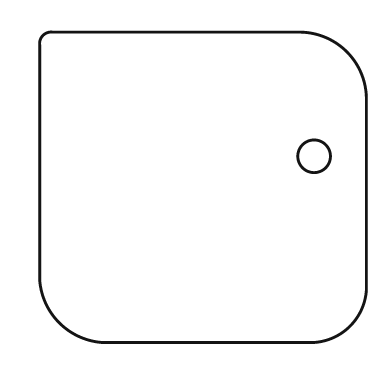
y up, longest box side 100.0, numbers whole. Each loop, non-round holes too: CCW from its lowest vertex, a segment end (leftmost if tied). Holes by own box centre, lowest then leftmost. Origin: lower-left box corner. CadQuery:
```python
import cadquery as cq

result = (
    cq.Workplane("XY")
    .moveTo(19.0, 0.0)
    .lineTo(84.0, 0.0)
    .threePointArc((95.0, 5.0), (100.0, 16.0))
    .lineTo(100.0, 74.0)
    .threePointArc((94.0, 89.0), (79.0, 95.0))
    .lineTo(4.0, 95.0)
    .threePointArc((1.0, 94.0), (0.0, 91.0))
    .lineTo(0.0, 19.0)
    .threePointArc((6.0, 6.0), (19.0, 0.0))
    .close()
    .moveTo(84.0, 57.0)
    .circle(5.0)
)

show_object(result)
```